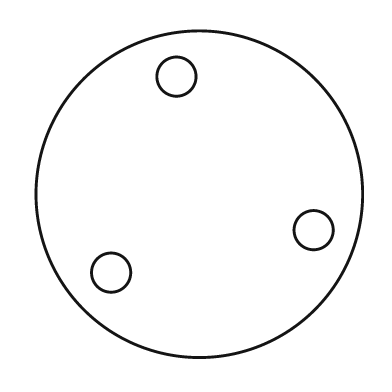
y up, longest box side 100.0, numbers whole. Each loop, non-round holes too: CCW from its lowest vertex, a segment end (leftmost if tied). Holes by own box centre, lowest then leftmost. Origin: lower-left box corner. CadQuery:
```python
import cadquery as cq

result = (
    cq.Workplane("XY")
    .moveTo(50.0, 50.0)
    .circle(50.0)
    .moveTo(23.0, 26.0)
    .circle(6.0)
    .moveTo(85.0, 39.0)
    .circle(6.0)
    .moveTo(43.0, 86.0)
    .circle(6.0)
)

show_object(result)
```